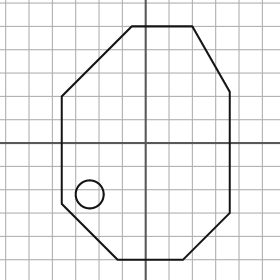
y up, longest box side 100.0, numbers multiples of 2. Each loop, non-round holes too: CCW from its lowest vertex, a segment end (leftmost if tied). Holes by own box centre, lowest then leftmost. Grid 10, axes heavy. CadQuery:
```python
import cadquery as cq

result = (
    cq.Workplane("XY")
    .moveTo(-12.0, -50.0)
    .lineTo(16.0, -50.0)
    .lineTo(36.0, -30.0)
    .lineTo(36.0, 22.0)
    .lineTo(20.0, 50.0)
    .lineTo(-6.0, 50.0)
    .lineTo(-36.0, 20.0)
    .lineTo(-36.0, -26.0)
    .close()
    .moveTo(-24.0, -22.0)
    .circle(6.0)
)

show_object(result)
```